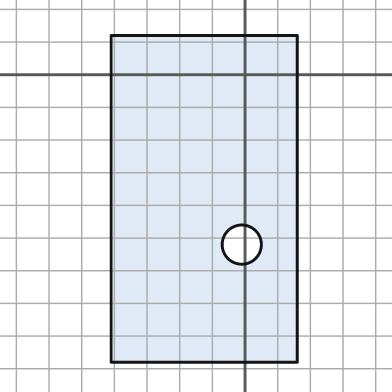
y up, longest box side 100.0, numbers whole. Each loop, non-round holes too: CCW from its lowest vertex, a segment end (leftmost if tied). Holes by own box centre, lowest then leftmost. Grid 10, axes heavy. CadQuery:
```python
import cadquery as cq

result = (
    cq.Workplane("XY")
    .moveTo(-41.0, -88.0)
    .lineTo(16.0, -88.0)
    .lineTo(16.0, 12.0)
    .lineTo(-41.0, 12.0)
    .close()
    .moveTo(-1.0, -52.0)
    .circle(6.0)
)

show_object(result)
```